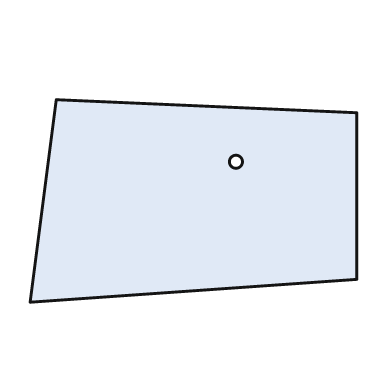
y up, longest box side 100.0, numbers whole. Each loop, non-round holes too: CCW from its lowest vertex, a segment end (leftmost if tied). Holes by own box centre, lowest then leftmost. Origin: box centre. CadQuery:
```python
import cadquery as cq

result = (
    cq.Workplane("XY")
    .moveTo(-50.0, -31.0)
    .lineTo(50.0, -24.0)
    .lineTo(50.0, 27.0)
    .lineTo(-42.0, 31.0)
    .close()
    .moveTo(13.0, 12.0)
    .circle(2.0)
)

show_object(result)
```